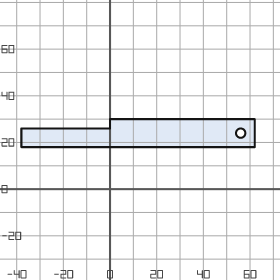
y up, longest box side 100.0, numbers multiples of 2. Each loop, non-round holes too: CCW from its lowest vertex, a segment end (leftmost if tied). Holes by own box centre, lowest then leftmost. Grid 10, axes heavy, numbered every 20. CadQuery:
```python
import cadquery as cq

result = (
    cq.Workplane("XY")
    .moveTo(-38.0, 18.0)
    .lineTo(62.0, 18.0)
    .lineTo(62.0, 30.0)
    .lineTo(0.0, 30.0)
    .lineTo(0.0, 26.0)
    .lineTo(-38.0, 26.0)
    .close()
    .moveTo(56.0, 24.0)
    .circle(2.0)
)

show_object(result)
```